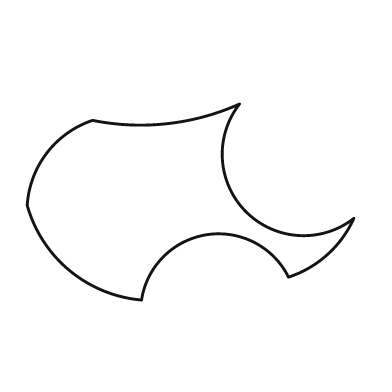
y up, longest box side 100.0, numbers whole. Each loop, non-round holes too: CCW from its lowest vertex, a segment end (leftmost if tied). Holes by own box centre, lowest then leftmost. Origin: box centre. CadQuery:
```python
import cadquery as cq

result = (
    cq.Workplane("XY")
    .moveTo(-15.0, -30.0)
    .threePointArc((5.0, -10.0), (30.0, -23.0))
    .threePointArc((42.0, -16.0), (50.0, -5.0))
    .threePointArc((17.0, -3.0), (15.0, 30.0))
    .threePointArc((-7.0, 24.0), (-30.0, 25.0))
    .threePointArc((-44.0, 15.0), (-50.0, -1.0))
    .threePointArc((-37.0, -21.0), (-15.0, -30.0))
    .close()
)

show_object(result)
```